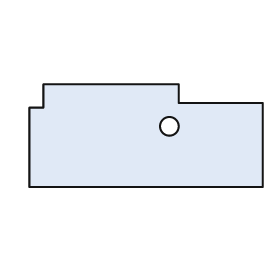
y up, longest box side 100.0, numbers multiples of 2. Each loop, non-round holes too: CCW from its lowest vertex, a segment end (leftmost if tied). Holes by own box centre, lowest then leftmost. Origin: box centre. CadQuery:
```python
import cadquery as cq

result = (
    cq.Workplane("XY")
    .moveTo(-50.0, -22.0)
    .lineTo(50.0, -22.0)
    .lineTo(50.0, 14.0)
    .lineTo(14.0, 14.0)
    .lineTo(14.0, 22.0)
    .lineTo(-44.0, 22.0)
    .lineTo(-44.0, 12.0)
    .lineTo(-50.0, 12.0)
    .close()
    .moveTo(10.0, 4.0)
    .circle(4.0)
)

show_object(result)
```